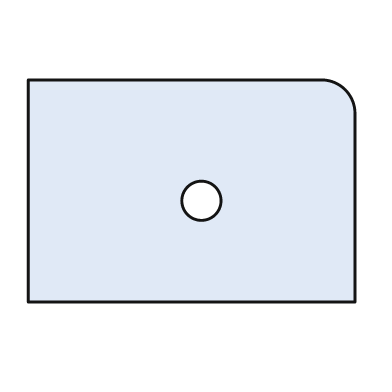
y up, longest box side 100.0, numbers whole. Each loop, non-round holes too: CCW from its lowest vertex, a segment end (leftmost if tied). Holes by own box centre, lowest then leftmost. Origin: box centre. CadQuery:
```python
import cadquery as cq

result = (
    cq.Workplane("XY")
    .moveTo(-50.0, -34.0)
    .lineTo(50.0, -34.0)
    .lineTo(50.0, 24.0)
    .threePointArc((47.0, 31.0), (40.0, 34.0))
    .lineTo(-50.0, 34.0)
    .close()
    .moveTo(3.0, -3.0)
    .circle(6.0)
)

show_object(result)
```